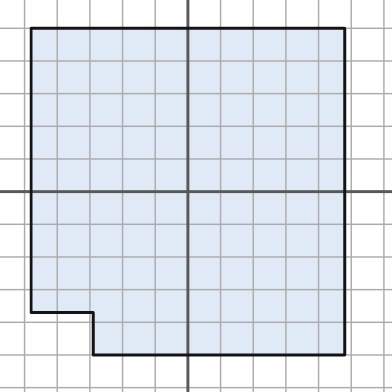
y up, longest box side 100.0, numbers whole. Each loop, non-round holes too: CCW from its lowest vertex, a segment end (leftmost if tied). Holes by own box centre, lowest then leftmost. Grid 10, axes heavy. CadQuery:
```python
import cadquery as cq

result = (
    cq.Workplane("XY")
    .moveTo(-29.0, -50.0)
    .lineTo(48.0, -50.0)
    .lineTo(48.0, 50.0)
    .lineTo(-48.0, 50.0)
    .lineTo(-48.0, -37.0)
    .lineTo(-29.0, -37.0)
    .close()
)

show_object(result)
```